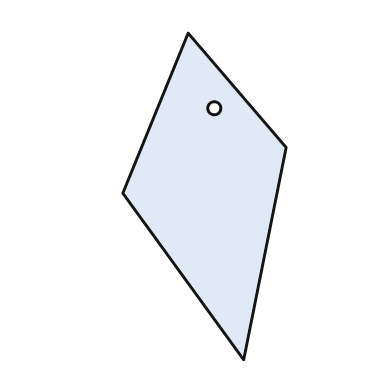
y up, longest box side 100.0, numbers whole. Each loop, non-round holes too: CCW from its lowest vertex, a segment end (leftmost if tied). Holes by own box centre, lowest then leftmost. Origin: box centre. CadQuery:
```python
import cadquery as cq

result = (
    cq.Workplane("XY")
    .moveTo(12.0, -50.0)
    .lineTo(25.0, 15.0)
    .lineTo(-5.0, 50.0)
    .lineTo(-25.0, 1.0)
    .close()
    .moveTo(3.0, 27.0)
    .circle(2.0)
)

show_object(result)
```